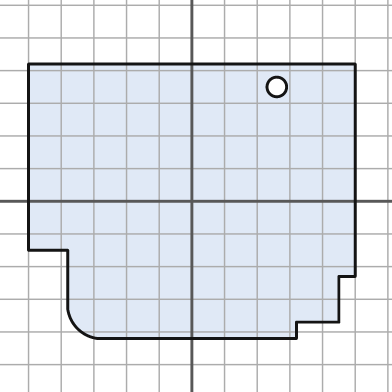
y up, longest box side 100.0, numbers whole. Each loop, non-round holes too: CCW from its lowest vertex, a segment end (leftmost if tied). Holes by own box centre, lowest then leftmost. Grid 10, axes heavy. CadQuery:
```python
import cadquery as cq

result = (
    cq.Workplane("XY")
    .moveTo(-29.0, -42.0)
    .lineTo(32.0, -42.0)
    .lineTo(32.0, -37.0)
    .lineTo(45.0, -37.0)
    .lineTo(45.0, -23.0)
    .lineTo(50.0, -23.0)
    .lineTo(50.0, 42.0)
    .lineTo(-50.0, 42.0)
    .lineTo(-50.0, -15.0)
    .lineTo(-38.0, -15.0)
    .lineTo(-38.0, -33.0)
    .threePointArc((-35.0, -39.0), (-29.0, -42.0))
    .close()
    .moveTo(26.0, 35.0)
    .circle(3.0)
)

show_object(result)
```